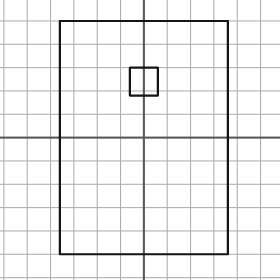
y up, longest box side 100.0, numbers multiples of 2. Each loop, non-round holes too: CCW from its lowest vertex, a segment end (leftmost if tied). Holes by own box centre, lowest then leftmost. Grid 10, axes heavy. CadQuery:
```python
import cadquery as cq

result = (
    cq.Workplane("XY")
    .moveTo(-36.0, -50.0)
    .lineTo(36.0, -50.0)
    .lineTo(36.0, 50.0)
    .lineTo(-36.0, 50.0)
    .close()
    .moveTo(-6.0, 18.0)
    .lineTo(6.0, 18.0)
    .lineTo(6.0, 30.0)
    .lineTo(-6.0, 30.0)
    .close()
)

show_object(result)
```